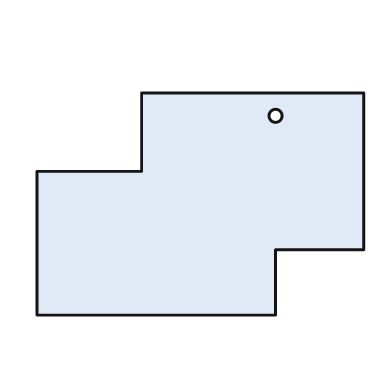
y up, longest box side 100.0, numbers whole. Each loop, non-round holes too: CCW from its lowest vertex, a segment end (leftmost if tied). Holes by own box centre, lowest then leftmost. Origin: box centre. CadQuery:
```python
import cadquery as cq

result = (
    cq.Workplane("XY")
    .moveTo(-50.0, -34.0)
    .lineTo(23.0, -34.0)
    .lineTo(23.0, -14.0)
    .lineTo(50.0, -14.0)
    .lineTo(50.0, 34.0)
    .lineTo(-18.0, 34.0)
    .lineTo(-18.0, 10.0)
    .lineTo(-50.0, 10.0)
    .close()
    .moveTo(23.0, 27.0)
    .circle(2.0)
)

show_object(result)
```